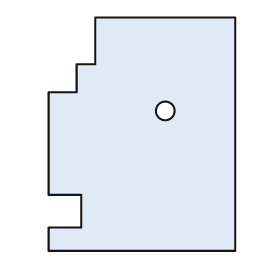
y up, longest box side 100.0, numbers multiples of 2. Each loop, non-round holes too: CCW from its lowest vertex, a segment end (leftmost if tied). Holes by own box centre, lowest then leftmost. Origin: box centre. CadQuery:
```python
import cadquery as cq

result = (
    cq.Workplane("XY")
    .moveTo(-40.0, -50.0)
    .lineTo(40.0, -50.0)
    .lineTo(40.0, 50.0)
    .lineTo(-20.0, 50.0)
    .lineTo(-20.0, 30.0)
    .lineTo(-28.0, 30.0)
    .lineTo(-28.0, 18.0)
    .lineTo(-40.0, 18.0)
    .lineTo(-40.0, -26.0)
    .lineTo(-26.0, -26.0)
    .lineTo(-26.0, -40.0)
    .lineTo(-40.0, -40.0)
    .close()
    .moveTo(10.0, 10.0)
    .circle(4.0)
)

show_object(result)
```